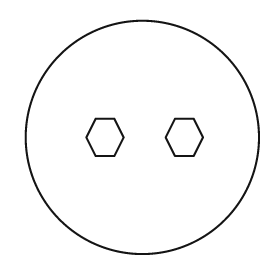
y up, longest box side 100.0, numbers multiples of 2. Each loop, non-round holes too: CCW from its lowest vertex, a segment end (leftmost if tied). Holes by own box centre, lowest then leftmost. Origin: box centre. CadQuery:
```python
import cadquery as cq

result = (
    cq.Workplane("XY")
    .moveTo(0.0, 0.0)
    .circle(50.0)
    .moveTo(-20.0, -8.0)
    .lineTo(-12.0, -8.0)
    .lineTo(-8.0, 0.0)
    .lineTo(-12.0, 8.0)
    .lineTo(-20.0, 8.0)
    .lineTo(-24.0, 0.0)
    .close()
    .moveTo(14.0, -8.0)
    .lineTo(22.0, -8.0)
    .lineTo(26.0, 0.0)
    .lineTo(22.0, 8.0)
    .lineTo(14.0, 8.0)
    .lineTo(10.0, 0.0)
    .close()
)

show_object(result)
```